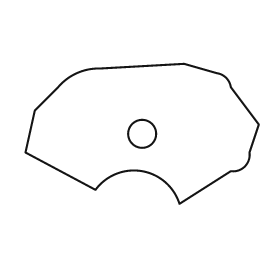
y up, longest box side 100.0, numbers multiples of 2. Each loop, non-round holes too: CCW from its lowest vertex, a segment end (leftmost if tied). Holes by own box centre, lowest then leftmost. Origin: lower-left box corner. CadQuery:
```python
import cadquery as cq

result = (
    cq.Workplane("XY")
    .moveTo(66.0, 0.0)
    .lineTo(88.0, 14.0)
    .threePointArc((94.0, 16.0), (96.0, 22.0))
    .lineTo(100.0, 34.0)
    .lineTo(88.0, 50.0)
    .threePointArc((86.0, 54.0), (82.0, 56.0))
    .lineTo(68.0, 60.0)
    .lineTo(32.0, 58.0)
    .threePointArc((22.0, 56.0), (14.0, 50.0))
    .lineTo(4.0, 40.0)
    .lineTo(0.0, 22.0)
    .lineTo(30.0, 6.0)
    .threePointArc((50.0, 14.0), (66.0, 0.0))
    .close()
    .moveTo(50.0, 30.0)
    .circle(6.0)
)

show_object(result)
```